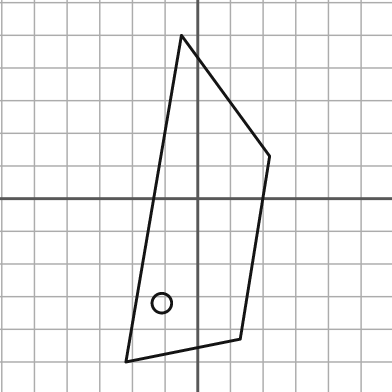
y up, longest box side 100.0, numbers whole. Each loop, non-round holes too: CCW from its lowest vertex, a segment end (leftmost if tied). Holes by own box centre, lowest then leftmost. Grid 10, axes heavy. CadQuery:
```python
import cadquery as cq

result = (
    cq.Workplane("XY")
    .moveTo(-22.0, -50.0)
    .lineTo(13.0, -43.0)
    .lineTo(22.0, 13.0)
    .lineTo(-5.0, 50.0)
    .close()
    .moveTo(-11.0, -32.0)
    .circle(3.0)
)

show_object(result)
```